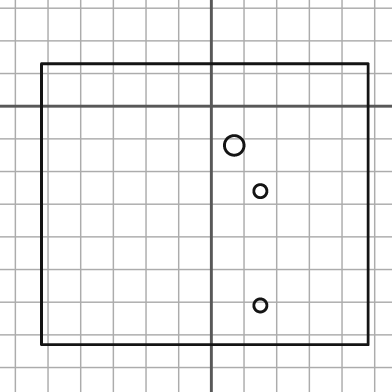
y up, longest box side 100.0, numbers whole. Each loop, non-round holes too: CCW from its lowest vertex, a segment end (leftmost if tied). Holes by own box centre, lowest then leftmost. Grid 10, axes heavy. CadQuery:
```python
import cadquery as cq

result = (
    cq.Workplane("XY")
    .moveTo(-52.0, -73.0)
    .lineTo(48.0, -73.0)
    .lineTo(48.0, 13.0)
    .lineTo(-52.0, 13.0)
    .close()
    .moveTo(15.0, -61.0)
    .circle(2.0)
    .moveTo(15.0, -26.0)
    .circle(2.0)
    .moveTo(7.0, -12.0)
    .circle(3.0)
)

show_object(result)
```